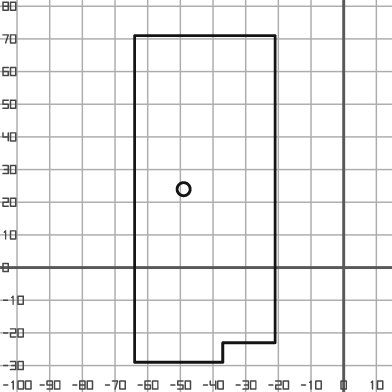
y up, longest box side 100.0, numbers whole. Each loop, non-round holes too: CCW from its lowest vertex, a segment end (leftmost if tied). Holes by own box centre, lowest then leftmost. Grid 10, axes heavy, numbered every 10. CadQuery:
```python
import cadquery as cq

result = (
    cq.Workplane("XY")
    .moveTo(-64.0, -29.0)
    .lineTo(-37.0, -29.0)
    .lineTo(-37.0, -23.0)
    .lineTo(-21.0, -23.0)
    .lineTo(-21.0, 71.0)
    .lineTo(-64.0, 71.0)
    .close()
    .moveTo(-49.0, 24.0)
    .circle(2.0)
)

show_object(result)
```